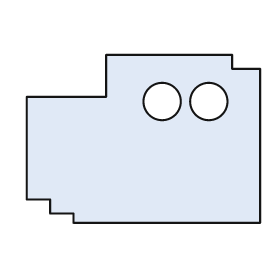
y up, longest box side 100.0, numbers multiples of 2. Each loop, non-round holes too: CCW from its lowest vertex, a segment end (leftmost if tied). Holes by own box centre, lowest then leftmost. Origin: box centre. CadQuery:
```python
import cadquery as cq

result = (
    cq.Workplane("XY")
    .moveTo(-30.0, -36.0)
    .lineTo(50.0, -36.0)
    .lineTo(50.0, 30.0)
    .lineTo(38.0, 30.0)
    .lineTo(38.0, 36.0)
    .lineTo(-16.0, 36.0)
    .lineTo(-16.0, 18.0)
    .lineTo(-50.0, 18.0)
    .lineTo(-50.0, -26.0)
    .lineTo(-40.0, -26.0)
    .lineTo(-40.0, -32.0)
    .lineTo(-30.0, -32.0)
    .close()
    .moveTo(8.0, 16.0)
    .circle(8.0)
    .moveTo(28.0, 16.0)
    .circle(8.0)
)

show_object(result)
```